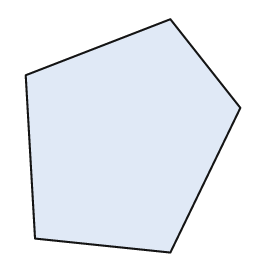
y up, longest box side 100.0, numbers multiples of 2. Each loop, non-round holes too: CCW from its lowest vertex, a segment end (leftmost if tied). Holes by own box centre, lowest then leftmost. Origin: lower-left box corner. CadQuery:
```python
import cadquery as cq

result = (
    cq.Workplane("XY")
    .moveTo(62.0, 0.0)
    .lineTo(92.0, 62.0)
    .lineTo(62.0, 100.0)
    .lineTo(0.0, 76.0)
    .lineTo(4.0, 6.0)
    .close()
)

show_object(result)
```